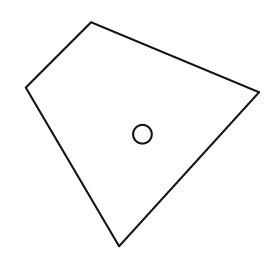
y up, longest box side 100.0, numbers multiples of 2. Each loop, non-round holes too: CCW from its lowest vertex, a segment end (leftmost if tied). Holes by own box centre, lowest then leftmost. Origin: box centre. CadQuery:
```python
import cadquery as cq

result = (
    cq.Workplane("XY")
    .moveTo(-10.0, -48.0)
    .lineTo(50.0, 18.0)
    .lineTo(-22.0, 48.0)
    .lineTo(-50.0, 20.0)
    .close()
    .moveTo(0.0, 0.0)
    .circle(4.0)
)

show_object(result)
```